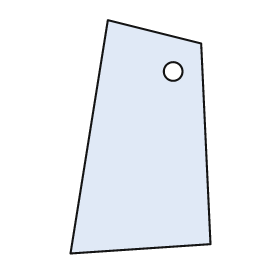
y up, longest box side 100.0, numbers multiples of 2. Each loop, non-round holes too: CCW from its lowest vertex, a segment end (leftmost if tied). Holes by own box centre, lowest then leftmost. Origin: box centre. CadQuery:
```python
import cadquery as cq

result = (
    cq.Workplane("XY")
    .moveTo(-30.0, -50.0)
    .lineTo(30.0, -46.0)
    .lineTo(26.0, 40.0)
    .lineTo(-14.0, 50.0)
    .close()
    .moveTo(14.0, 28.0)
    .circle(4.0)
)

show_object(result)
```